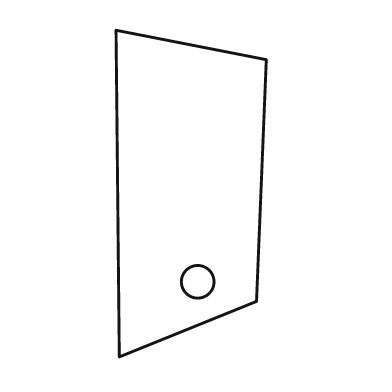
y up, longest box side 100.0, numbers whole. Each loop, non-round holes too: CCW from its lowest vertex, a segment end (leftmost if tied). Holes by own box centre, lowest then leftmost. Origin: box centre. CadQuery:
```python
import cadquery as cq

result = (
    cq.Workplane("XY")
    .moveTo(-22.0, -50.0)
    .lineTo(20.0, -33.0)
    .lineTo(23.0, 41.0)
    .lineTo(-23.0, 50.0)
    .close()
    .moveTo(2.0, -27.0)
    .circle(5.0)
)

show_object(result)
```